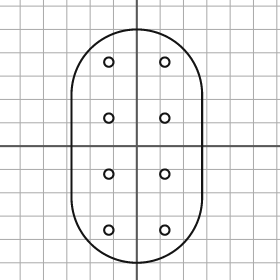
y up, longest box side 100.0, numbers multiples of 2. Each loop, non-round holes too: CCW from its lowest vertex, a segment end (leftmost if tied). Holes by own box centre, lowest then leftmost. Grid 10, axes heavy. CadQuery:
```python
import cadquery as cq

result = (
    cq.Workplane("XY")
    .moveTo(-28.0, -22.0)
    .threePointArc((0.0, -50.0), (28.0, -22.0))
    .lineTo(28.0, 22.0)
    .threePointArc((0.0, 50.0), (-28.0, 22.0))
    .close()
    .moveTo(-12.0, -36.0)
    .circle(2.0)
    .moveTo(12.0, -36.0)
    .circle(2.0)
    .moveTo(-12.0, -12.0)
    .circle(2.0)
    .moveTo(12.0, -12.0)
    .circle(2.0)
    .moveTo(-12.0, 12.0)
    .circle(2.0)
    .moveTo(12.0, 12.0)
    .circle(2.0)
    .moveTo(-12.0, 36.0)
    .circle(2.0)
    .moveTo(12.0, 36.0)
    .circle(2.0)
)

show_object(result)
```